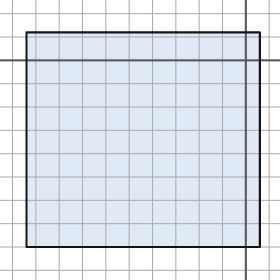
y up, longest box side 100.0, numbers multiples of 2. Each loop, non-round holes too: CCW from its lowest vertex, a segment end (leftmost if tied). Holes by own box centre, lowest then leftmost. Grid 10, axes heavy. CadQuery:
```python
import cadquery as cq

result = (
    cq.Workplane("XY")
    .moveTo(-94.0, -80.0)
    .lineTo(6.0, -80.0)
    .lineTo(6.0, 12.0)
    .lineTo(-94.0, 12.0)
    .close()
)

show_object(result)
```